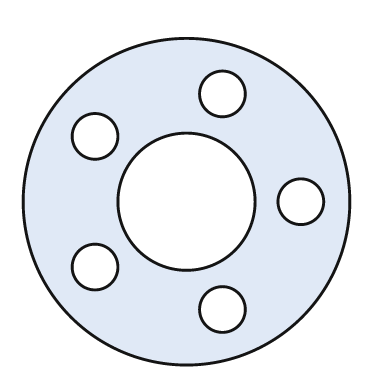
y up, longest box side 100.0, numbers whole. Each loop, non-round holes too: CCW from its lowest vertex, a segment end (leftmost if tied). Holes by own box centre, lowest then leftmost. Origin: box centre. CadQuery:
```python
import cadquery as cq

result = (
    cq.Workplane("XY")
    .moveTo(0.0, 0.0)
    .circle(50.0)
    .moveTo(11.0, -33.0)
    .circle(7.0)
    .moveTo(-28.0, -20.0)
    .circle(7.0)
    .moveTo(0.0, 0.0)
    .circle(21.0)
    .moveTo(35.0, 0.0)
    .circle(7.0)
    .moveTo(-28.0, 20.0)
    .circle(7.0)
    .moveTo(11.0, 33.0)
    .circle(7.0)
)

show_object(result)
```